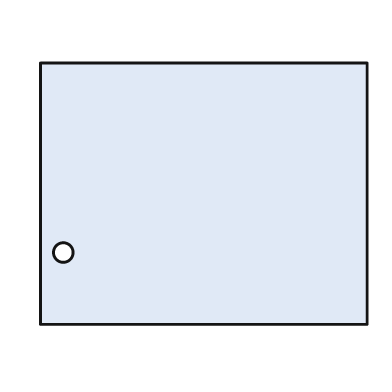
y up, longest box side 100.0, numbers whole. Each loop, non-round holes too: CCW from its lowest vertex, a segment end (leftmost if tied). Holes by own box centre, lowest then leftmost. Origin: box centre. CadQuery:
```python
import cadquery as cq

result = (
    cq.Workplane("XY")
    .moveTo(-50.0, -40.0)
    .lineTo(50.0, -40.0)
    .lineTo(50.0, 40.0)
    .lineTo(-50.0, 40.0)
    .close()
    .moveTo(-43.0, -18.0)
    .circle(3.0)
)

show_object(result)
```